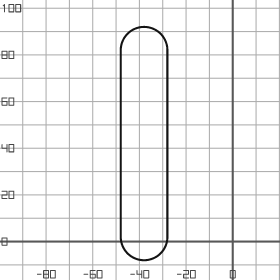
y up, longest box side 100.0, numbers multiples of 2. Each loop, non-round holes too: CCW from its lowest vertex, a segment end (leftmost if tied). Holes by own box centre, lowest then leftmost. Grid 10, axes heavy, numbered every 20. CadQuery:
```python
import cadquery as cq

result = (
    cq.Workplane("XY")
    .moveTo(-48.0, 2.0)
    .threePointArc((-38.0, -8.0), (-28.0, 2.0))
    .lineTo(-28.0, 82.0)
    .threePointArc((-38.0, 92.0), (-48.0, 82.0))
    .close()
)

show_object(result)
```